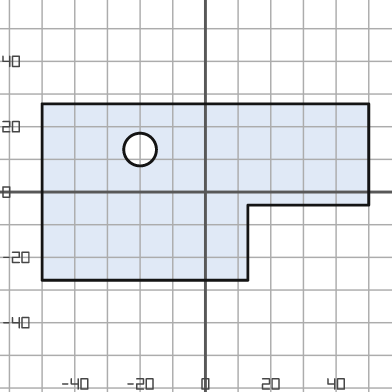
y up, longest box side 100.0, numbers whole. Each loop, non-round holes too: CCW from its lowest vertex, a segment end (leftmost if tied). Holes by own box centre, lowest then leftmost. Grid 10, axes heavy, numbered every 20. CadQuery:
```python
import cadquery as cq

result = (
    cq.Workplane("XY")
    .moveTo(-50.0, -27.0)
    .lineTo(13.0, -27.0)
    .lineTo(13.0, -4.0)
    .lineTo(50.0, -4.0)
    .lineTo(50.0, 27.0)
    .lineTo(-50.0, 27.0)
    .close()
    .moveTo(-20.0, 13.0)
    .circle(5.0)
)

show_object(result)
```